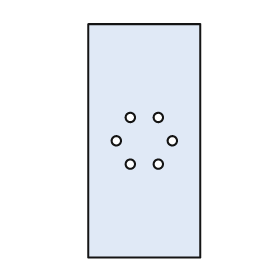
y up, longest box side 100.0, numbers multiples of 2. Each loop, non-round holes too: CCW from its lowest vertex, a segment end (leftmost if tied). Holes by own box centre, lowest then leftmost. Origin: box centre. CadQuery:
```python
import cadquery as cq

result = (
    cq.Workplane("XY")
    .moveTo(-24.0, -50.0)
    .lineTo(24.0, -50.0)
    .lineTo(24.0, 50.0)
    .lineTo(-24.0, 50.0)
    .close()
    .moveTo(-6.0, -10.0)
    .circle(2.0)
    .moveTo(6.0, -10.0)
    .circle(2.0)
    .moveTo(-12.0, 0.0)
    .circle(2.0)
    .moveTo(12.0, 0.0)
    .circle(2.0)
    .moveTo(-6.0, 10.0)
    .circle(2.0)
    .moveTo(6.0, 10.0)
    .circle(2.0)
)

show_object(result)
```